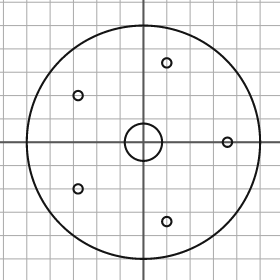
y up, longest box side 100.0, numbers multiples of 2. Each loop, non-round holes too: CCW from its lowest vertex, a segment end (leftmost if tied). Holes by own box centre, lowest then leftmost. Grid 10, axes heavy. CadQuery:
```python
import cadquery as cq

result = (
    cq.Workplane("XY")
    .moveTo(0.0, 0.0)
    .circle(50.0)
    .moveTo(10.0, -34.0)
    .circle(2.0)
    .moveTo(-28.0, -20.0)
    .circle(2.0)
    .moveTo(0.0, 0.0)
    .circle(8.0)
    .moveTo(36.0, 0.0)
    .circle(2.0)
    .moveTo(-28.0, 20.0)
    .circle(2.0)
    .moveTo(10.0, 34.0)
    .circle(2.0)
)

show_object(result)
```